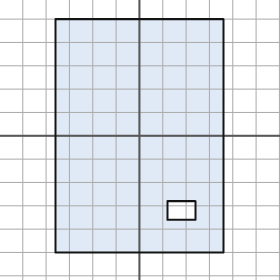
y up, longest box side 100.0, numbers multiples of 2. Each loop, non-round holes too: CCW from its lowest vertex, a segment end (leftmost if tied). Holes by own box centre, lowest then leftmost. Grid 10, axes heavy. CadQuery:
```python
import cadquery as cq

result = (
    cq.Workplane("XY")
    .moveTo(-36.0, -50.0)
    .lineTo(36.0, -50.0)
    .lineTo(36.0, 50.0)
    .lineTo(-36.0, 50.0)
    .close()
    .moveTo(12.0, -36.0)
    .lineTo(24.0, -36.0)
    .lineTo(24.0, -28.0)
    .lineTo(12.0, -28.0)
    .close()
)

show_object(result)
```